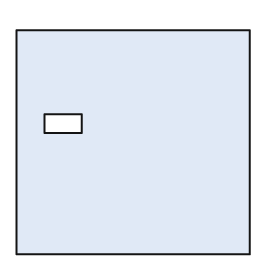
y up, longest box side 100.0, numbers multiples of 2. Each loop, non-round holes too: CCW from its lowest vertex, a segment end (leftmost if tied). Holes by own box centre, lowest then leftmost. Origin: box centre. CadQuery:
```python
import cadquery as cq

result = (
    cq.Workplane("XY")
    .moveTo(-50.0, -48.0)
    .lineTo(50.0, -48.0)
    .lineTo(50.0, 48.0)
    .lineTo(-50.0, 48.0)
    .close()
    .moveTo(-38.0, 4.0)
    .lineTo(-22.0, 4.0)
    .lineTo(-22.0, 12.0)
    .lineTo(-38.0, 12.0)
    .close()
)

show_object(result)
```